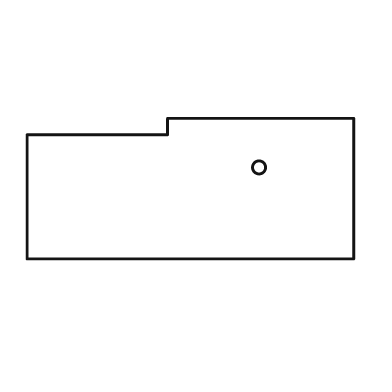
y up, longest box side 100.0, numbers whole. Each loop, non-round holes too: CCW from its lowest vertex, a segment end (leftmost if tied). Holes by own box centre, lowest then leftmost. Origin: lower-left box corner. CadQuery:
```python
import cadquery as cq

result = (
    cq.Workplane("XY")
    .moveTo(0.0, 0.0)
    .lineTo(100.0, 0.0)
    .lineTo(100.0, 43.0)
    .lineTo(43.0, 43.0)
    .lineTo(43.0, 38.0)
    .lineTo(0.0, 38.0)
    .close()
    .moveTo(71.0, 28.0)
    .circle(2.0)
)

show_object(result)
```